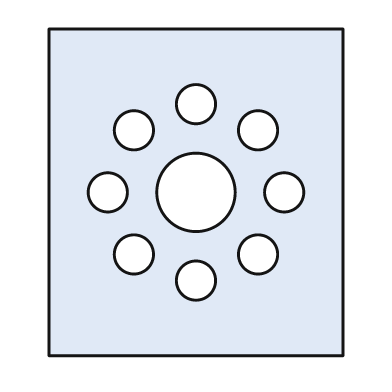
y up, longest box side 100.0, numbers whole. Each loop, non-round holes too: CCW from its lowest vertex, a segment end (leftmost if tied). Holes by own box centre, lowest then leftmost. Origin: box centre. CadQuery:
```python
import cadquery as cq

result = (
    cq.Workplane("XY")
    .moveTo(-45.0, -50.0)
    .lineTo(45.0, -50.0)
    .lineTo(45.0, 50.0)
    .lineTo(-45.0, 50.0)
    .close()
    .moveTo(0.0, -27.0)
    .circle(6.0)
    .moveTo(-19.0, -19.0)
    .circle(6.0)
    .moveTo(19.0, -19.0)
    .circle(6.0)
    .moveTo(-27.0, 0.0)
    .circle(6.0)
    .moveTo(0.0, 0.0)
    .circle(12.0)
    .moveTo(27.0, 0.0)
    .circle(6.0)
    .moveTo(-19.0, 19.0)
    .circle(6.0)
    .moveTo(19.0, 19.0)
    .circle(6.0)
    .moveTo(0.0, 27.0)
    .circle(6.0)
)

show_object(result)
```